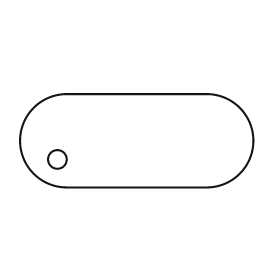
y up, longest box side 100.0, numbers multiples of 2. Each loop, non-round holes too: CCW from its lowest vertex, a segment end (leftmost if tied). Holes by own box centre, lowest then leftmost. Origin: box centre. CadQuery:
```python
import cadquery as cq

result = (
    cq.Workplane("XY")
    .moveTo(-30.0, -20.0)
    .lineTo(30.0, -20.0)
    .threePointArc((50.0, 0.0), (30.0, 20.0))
    .lineTo(-30.0, 20.0)
    .threePointArc((-50.0, 0.0), (-30.0, -20.0))
    .close()
    .moveTo(-34.0, -8.0)
    .circle(4.0)
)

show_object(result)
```